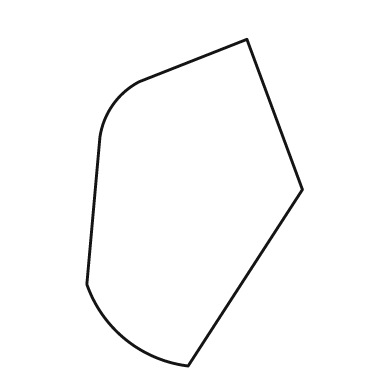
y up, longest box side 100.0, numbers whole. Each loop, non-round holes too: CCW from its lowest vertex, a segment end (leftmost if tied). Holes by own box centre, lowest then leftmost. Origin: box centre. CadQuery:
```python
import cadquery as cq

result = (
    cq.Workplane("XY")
    .moveTo(-2.0, -50.0)
    .lineTo(33.0, 4.0)
    .lineTo(16.0, 50.0)
    .lineTo(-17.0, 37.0)
    .threePointArc((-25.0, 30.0), (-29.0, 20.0))
    .lineTo(-33.0, -25.0)
    .threePointArc((-21.0, -42.0), (-2.0, -50.0))
    .close()
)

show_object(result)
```